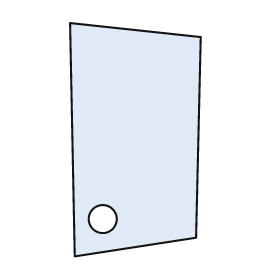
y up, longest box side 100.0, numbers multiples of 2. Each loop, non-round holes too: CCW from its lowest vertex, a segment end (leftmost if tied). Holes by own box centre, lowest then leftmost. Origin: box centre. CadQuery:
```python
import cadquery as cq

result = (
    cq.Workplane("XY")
    .moveTo(-26.0, -50.0)
    .lineTo(26.0, -42.0)
    .lineTo(28.0, 44.0)
    .lineTo(-28.0, 50.0)
    .close()
    .moveTo(-14.0, -34.0)
    .circle(6.0)
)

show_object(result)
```